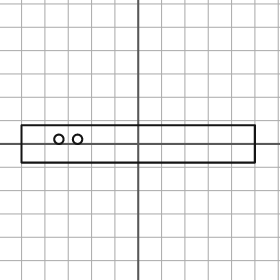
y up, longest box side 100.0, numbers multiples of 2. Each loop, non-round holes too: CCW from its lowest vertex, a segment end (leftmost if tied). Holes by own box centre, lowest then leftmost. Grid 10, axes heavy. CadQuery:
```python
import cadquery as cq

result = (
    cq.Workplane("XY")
    .moveTo(-50.0, -8.0)
    .lineTo(50.0, -8.0)
    .lineTo(50.0, 8.0)
    .lineTo(-50.0, 8.0)
    .close()
    .moveTo(-34.0, 2.0)
    .circle(2.0)
    .moveTo(-26.0, 2.0)
    .circle(2.0)
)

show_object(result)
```